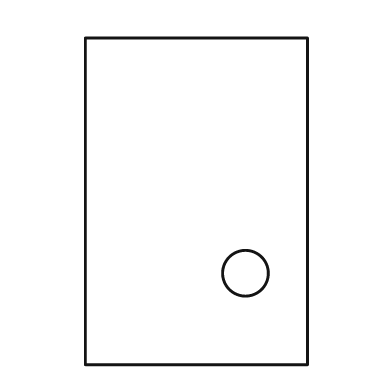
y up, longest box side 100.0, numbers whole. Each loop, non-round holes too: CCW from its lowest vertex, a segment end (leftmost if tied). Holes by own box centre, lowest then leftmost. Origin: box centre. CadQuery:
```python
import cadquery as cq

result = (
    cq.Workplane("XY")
    .moveTo(-34.0, -50.0)
    .lineTo(34.0, -50.0)
    .lineTo(34.0, 50.0)
    .lineTo(-34.0, 50.0)
    .close()
    .moveTo(15.0, -22.0)
    .circle(7.0)
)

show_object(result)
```